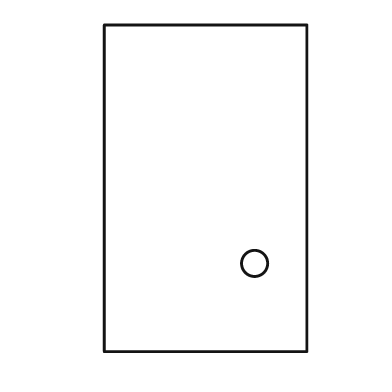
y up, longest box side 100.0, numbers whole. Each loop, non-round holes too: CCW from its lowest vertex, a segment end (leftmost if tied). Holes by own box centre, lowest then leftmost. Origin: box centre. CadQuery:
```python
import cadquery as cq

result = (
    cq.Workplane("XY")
    .moveTo(-31.0, -50.0)
    .lineTo(31.0, -50.0)
    .lineTo(31.0, 50.0)
    .lineTo(-31.0, 50.0)
    .close()
    .moveTo(15.0, -23.0)
    .circle(4.0)
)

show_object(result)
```